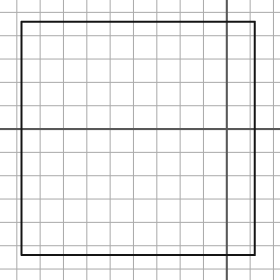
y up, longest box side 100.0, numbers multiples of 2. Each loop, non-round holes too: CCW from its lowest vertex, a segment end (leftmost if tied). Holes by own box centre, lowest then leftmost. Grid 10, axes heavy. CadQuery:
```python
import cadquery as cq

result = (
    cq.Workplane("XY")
    .moveTo(-88.0, -54.0)
    .lineTo(12.0, -54.0)
    .lineTo(12.0, 46.0)
    .lineTo(-88.0, 46.0)
    .close()
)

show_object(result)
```